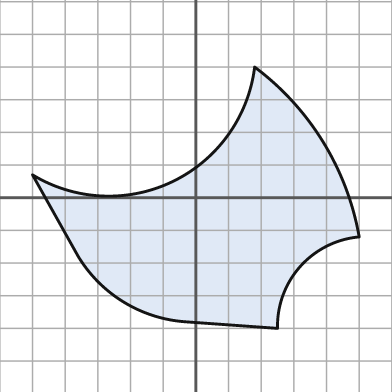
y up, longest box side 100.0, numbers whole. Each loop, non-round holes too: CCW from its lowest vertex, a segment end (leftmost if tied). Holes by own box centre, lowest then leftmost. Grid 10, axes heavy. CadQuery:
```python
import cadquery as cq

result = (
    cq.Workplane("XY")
    .moveTo(25.0, -40.0)
    .threePointArc((32.0, -21.0), (50.0, -12.0))
    .threePointArc((39.0, 17.0), (18.0, 40.0))
    .threePointArc((-7.0, 5.0), (-50.0, 7.0))
    .lineTo(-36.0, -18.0)
    .threePointArc((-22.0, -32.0), (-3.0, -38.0))
    .close()
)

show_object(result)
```